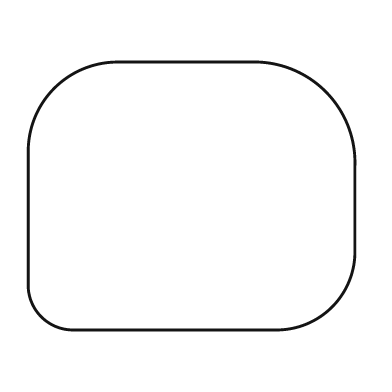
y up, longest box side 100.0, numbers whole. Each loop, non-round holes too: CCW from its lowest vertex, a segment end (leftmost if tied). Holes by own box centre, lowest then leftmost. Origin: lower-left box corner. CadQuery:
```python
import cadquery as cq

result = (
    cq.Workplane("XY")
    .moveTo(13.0, 0.0)
    .lineTo(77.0, 0.0)
    .threePointArc((93.0, 7.0), (100.0, 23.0))
    .lineTo(100.0, 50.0)
    .threePointArc((91.0, 73.0), (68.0, 82.0))
    .lineTo(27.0, 82.0)
    .threePointArc((8.0, 74.0), (0.0, 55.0))
    .lineTo(0.0, 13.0)
    .threePointArc((4.0, 4.0), (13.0, 0.0))
    .close()
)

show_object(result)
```